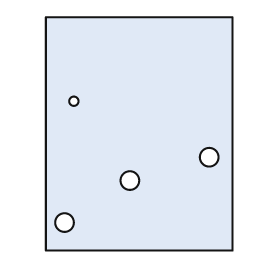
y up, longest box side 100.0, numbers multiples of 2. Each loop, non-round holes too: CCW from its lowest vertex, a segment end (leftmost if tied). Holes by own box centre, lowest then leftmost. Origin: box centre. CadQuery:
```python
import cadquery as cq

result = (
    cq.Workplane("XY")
    .moveTo(-40.0, -50.0)
    .lineTo(40.0, -50.0)
    .lineTo(40.0, 50.0)
    .lineTo(-40.0, 50.0)
    .close()
    .moveTo(-32.0, -38.0)
    .circle(4.0)
    .moveTo(-4.0, -20.0)
    .circle(4.0)
    .moveTo(30.0, -10.0)
    .circle(4.0)
    .moveTo(-28.0, 14.0)
    .circle(2.0)
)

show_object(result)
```